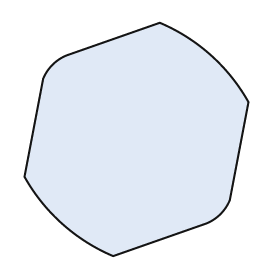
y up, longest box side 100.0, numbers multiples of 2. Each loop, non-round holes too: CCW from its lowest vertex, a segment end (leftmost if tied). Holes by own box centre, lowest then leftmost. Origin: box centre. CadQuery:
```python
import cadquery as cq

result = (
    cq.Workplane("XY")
    .moveTo(-10.0, -50.0)
    .lineTo(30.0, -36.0)
    .threePointArc((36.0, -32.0), (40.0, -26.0))
    .lineTo(48.0, 16.0)
    .threePointArc((32.0, 36.0), (10.0, 50.0))
    .lineTo(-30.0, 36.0)
    .threePointArc((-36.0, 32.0), (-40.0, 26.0))
    .lineTo(-48.0, -16.0)
    .threePointArc((-32.0, -36.0), (-10.0, -50.0))
    .close()
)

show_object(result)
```